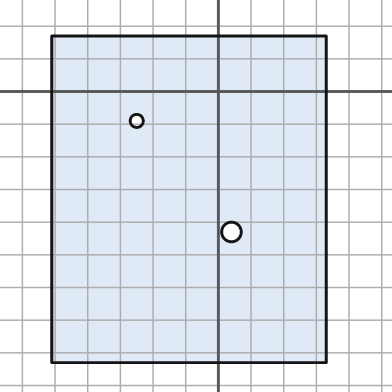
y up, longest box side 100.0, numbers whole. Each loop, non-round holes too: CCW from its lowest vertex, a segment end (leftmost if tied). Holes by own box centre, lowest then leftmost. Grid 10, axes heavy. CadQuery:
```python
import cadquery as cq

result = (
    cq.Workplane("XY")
    .moveTo(-51.0, -83.0)
    .lineTo(33.0, -83.0)
    .lineTo(33.0, 17.0)
    .lineTo(-51.0, 17.0)
    .close()
    .moveTo(4.0, -43.0)
    .circle(3.0)
    .moveTo(-25.0, -9.0)
    .circle(2.0)
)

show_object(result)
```